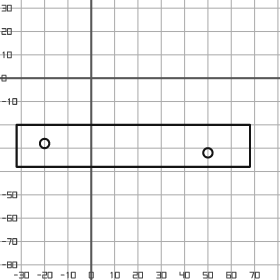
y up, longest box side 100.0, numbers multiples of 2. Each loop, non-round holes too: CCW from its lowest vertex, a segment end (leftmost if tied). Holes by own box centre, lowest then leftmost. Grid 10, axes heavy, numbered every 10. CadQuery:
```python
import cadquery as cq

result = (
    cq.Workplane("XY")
    .moveTo(-32.0, -38.0)
    .lineTo(68.0, -38.0)
    .lineTo(68.0, -20.0)
    .lineTo(-32.0, -20.0)
    .close()
    .moveTo(50.0, -32.0)
    .circle(2.0)
    .moveTo(-20.0, -28.0)
    .circle(2.0)
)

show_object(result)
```